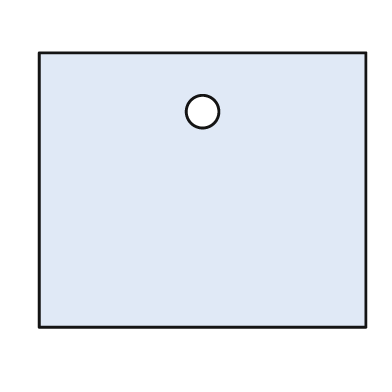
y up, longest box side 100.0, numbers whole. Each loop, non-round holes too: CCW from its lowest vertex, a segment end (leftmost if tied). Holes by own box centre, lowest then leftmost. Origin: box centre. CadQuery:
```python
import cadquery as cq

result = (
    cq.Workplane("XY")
    .moveTo(-50.0, -42.0)
    .lineTo(50.0, -42.0)
    .lineTo(50.0, 42.0)
    .lineTo(-50.0, 42.0)
    .close()
    .moveTo(0.0, 24.0)
    .circle(5.0)
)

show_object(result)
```